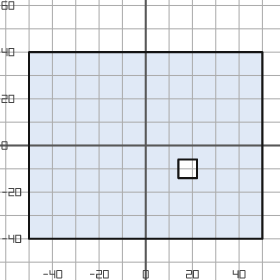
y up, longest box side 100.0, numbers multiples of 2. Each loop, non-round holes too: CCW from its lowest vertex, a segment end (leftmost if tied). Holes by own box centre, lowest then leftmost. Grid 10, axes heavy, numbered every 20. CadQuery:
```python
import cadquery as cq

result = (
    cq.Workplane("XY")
    .moveTo(-50.0, -40.0)
    .lineTo(50.0, -40.0)
    .lineTo(50.0, 40.0)
    .lineTo(-50.0, 40.0)
    .close()
    .moveTo(14.0, -14.0)
    .lineTo(22.0, -14.0)
    .lineTo(22.0, -6.0)
    .lineTo(14.0, -6.0)
    .close()
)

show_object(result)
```